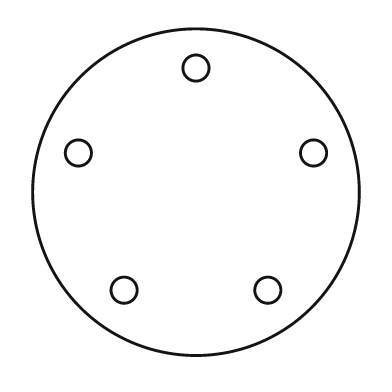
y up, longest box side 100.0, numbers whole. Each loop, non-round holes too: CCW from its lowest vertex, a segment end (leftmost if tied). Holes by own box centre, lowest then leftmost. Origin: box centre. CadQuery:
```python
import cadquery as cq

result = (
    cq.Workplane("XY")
    .moveTo(0.0, 0.0)
    .circle(50.0)
    .moveTo(-22.0, -30.0)
    .circle(4.0)
    .moveTo(22.0, -30.0)
    .circle(4.0)
    .moveTo(-36.0, 12.0)
    .circle(4.0)
    .moveTo(36.0, 12.0)
    .circle(4.0)
    .moveTo(0.0, 38.0)
    .circle(4.0)
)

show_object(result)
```